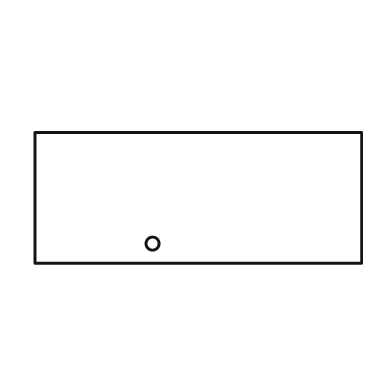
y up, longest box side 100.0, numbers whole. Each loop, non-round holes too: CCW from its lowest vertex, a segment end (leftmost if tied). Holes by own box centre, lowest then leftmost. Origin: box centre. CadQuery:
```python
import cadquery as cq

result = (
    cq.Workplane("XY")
    .moveTo(-50.0, -20.0)
    .lineTo(50.0, -20.0)
    .lineTo(50.0, 20.0)
    .lineTo(-50.0, 20.0)
    .close()
    .moveTo(-14.0, -14.0)
    .circle(2.0)
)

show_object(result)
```